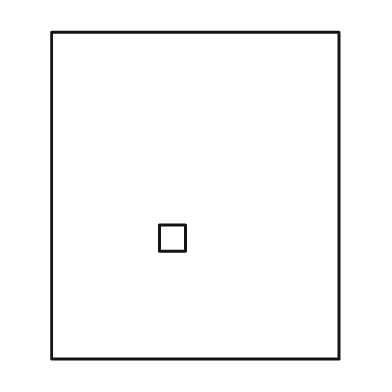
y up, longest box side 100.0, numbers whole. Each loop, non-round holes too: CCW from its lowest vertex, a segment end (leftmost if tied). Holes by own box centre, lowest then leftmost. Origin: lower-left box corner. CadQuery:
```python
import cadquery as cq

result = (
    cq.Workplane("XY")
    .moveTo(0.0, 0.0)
    .lineTo(88.0, 0.0)
    .lineTo(88.0, 100.0)
    .lineTo(0.0, 100.0)
    .close()
    .moveTo(33.0, 33.0)
    .lineTo(41.0, 33.0)
    .lineTo(41.0, 41.0)
    .lineTo(33.0, 41.0)
    .close()
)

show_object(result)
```